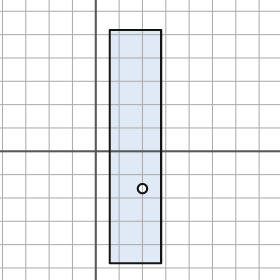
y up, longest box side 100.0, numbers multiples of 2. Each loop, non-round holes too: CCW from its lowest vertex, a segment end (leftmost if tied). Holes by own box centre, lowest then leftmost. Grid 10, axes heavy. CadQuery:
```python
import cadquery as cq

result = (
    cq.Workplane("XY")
    .moveTo(6.0, -48.0)
    .lineTo(28.0, -48.0)
    .lineTo(28.0, 52.0)
    .lineTo(6.0, 52.0)
    .close()
    .moveTo(20.0, -16.0)
    .circle(2.0)
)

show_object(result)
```